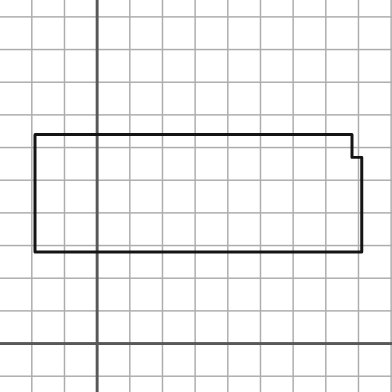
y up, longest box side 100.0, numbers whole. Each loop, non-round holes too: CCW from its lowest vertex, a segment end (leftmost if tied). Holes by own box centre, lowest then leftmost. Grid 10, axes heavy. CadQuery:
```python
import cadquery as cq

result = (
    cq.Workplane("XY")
    .moveTo(-19.0, 28.0)
    .lineTo(81.0, 28.0)
    .lineTo(81.0, 57.0)
    .lineTo(78.0, 57.0)
    .lineTo(78.0, 64.0)
    .lineTo(-19.0, 64.0)
    .close()
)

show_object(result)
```